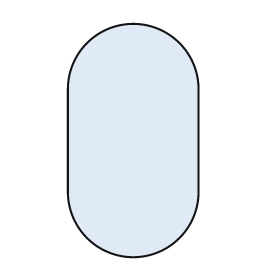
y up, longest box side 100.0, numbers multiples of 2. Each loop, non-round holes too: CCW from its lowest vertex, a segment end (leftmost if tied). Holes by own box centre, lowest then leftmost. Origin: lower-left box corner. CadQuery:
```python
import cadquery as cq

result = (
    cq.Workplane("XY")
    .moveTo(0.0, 28.0)
    .threePointArc((28.0, 0.0), (56.0, 28.0))
    .lineTo(56.0, 72.0)
    .threePointArc((28.0, 100.0), (0.0, 72.0))
    .close()
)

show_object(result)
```